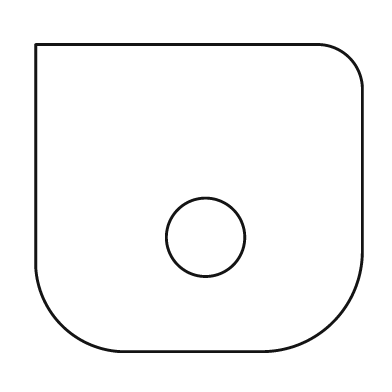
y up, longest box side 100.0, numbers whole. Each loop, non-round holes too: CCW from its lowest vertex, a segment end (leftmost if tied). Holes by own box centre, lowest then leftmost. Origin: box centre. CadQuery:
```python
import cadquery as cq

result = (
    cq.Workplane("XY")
    .moveTo(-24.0, -47.0)
    .lineTo(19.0, -47.0)
    .threePointArc((41.0, -38.0), (50.0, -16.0))
    .lineTo(50.0, 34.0)
    .threePointArc((46.0, 43.0), (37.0, 47.0))
    .lineTo(-50.0, 47.0)
    .lineTo(-50.0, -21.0)
    .threePointArc((-42.0, -39.0), (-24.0, -47.0))
    .close()
    .moveTo(2.0, -12.0)
    .circle(12.0)
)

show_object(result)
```